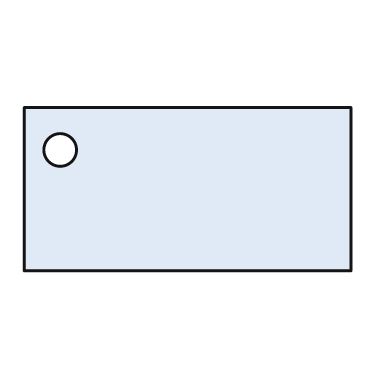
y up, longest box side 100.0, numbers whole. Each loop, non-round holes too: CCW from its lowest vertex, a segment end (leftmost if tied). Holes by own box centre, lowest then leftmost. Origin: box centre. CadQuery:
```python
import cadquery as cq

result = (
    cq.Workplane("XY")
    .moveTo(-50.0, -25.0)
    .lineTo(50.0, -25.0)
    .lineTo(50.0, 25.0)
    .lineTo(-50.0, 25.0)
    .close()
    .moveTo(-39.0, 12.0)
    .circle(5.0)
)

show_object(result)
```